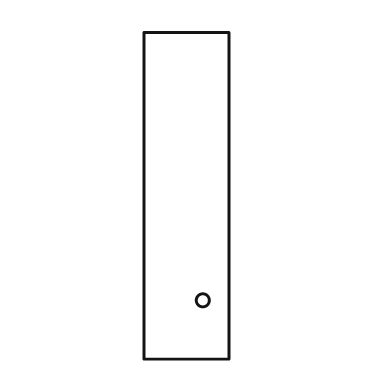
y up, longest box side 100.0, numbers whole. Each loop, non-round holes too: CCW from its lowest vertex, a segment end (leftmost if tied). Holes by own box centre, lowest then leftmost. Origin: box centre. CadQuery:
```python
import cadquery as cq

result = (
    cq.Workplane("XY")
    .moveTo(-13.0, -50.0)
    .lineTo(13.0, -50.0)
    .lineTo(13.0, 50.0)
    .lineTo(-13.0, 50.0)
    .close()
    .moveTo(5.0, -32.0)
    .circle(2.0)
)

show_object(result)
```